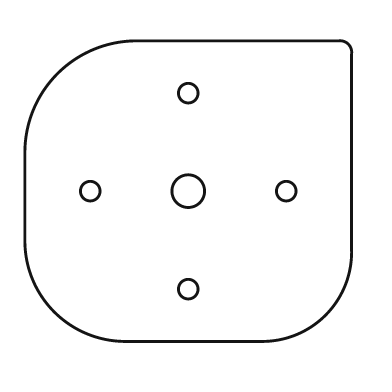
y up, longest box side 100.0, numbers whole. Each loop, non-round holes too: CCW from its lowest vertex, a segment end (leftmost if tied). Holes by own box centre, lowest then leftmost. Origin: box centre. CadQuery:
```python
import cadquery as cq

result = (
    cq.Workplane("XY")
    .moveTo(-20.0, -46.0)
    .lineTo(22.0, -46.0)
    .threePointArc((42.0, -38.0), (50.0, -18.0))
    .lineTo(50.0, 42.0)
    .threePointArc((49.0, 45.0), (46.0, 46.0))
    .lineTo(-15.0, 46.0)
    .threePointArc((-40.0, 36.0), (-50.0, 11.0))
    .lineTo(-50.0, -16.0)
    .threePointArc((-41.0, -37.0), (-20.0, -46.0))
    .close()
    .moveTo(0.0, -30.0)
    .circle(3.0)
    .moveTo(-30.0, 0.0)
    .circle(3.0)
    .moveTo(0.0, 0.0)
    .circle(5.0)
    .moveTo(30.0, 0.0)
    .circle(3.0)
    .moveTo(0.0, 30.0)
    .circle(3.0)
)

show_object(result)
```